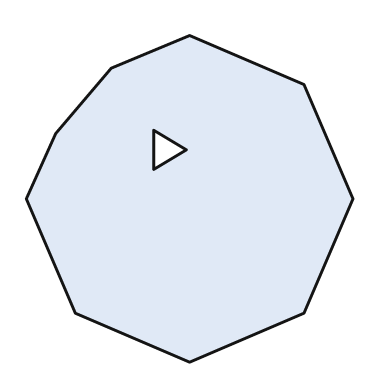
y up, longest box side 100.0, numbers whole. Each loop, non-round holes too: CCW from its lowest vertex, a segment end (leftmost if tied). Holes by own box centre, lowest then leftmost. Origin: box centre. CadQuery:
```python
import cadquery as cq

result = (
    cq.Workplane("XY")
    .moveTo(0.0, -50.0)
    .lineTo(35.0, -35.0)
    .lineTo(50.0, 0.0)
    .lineTo(35.0, 35.0)
    .lineTo(0.0, 50.0)
    .lineTo(-24.0, 40.0)
    .lineTo(-41.0, 20.0)
    .lineTo(-50.0, 0.0)
    .lineTo(-35.0, -35.0)
    .close()
    .moveTo(-11.0, 9.0)
    .lineTo(-1.0, 15.0)
    .lineTo(-11.0, 21.0)
    .close()
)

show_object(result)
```